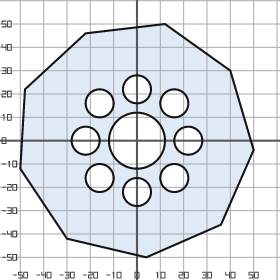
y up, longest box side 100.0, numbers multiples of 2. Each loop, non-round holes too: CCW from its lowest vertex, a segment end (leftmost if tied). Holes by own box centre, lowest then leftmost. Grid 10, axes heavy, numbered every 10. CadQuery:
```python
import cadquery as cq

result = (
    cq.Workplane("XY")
    .moveTo(4.0, -50.0)
    .lineTo(36.0, -36.0)
    .lineTo(50.0, -4.0)
    .lineTo(40.0, 30.0)
    .lineTo(12.0, 50.0)
    .lineTo(-22.0, 46.0)
    .lineTo(-48.0, 22.0)
    .lineTo(-50.0, -12.0)
    .lineTo(-30.0, -42.0)
    .close()
    .moveTo(0.0, -22.0)
    .circle(6.0)
    .moveTo(-16.0, -16.0)
    .circle(6.0)
    .moveTo(16.0, -16.0)
    .circle(6.0)
    .moveTo(-22.0, 0.0)
    .circle(6.0)
    .moveTo(0.0, 0.0)
    .circle(12.0)
    .moveTo(22.0, 0.0)
    .circle(6.0)
    .moveTo(-16.0, 16.0)
    .circle(6.0)
    .moveTo(16.0, 16.0)
    .circle(6.0)
    .moveTo(0.0, 22.0)
    .circle(6.0)
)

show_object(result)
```